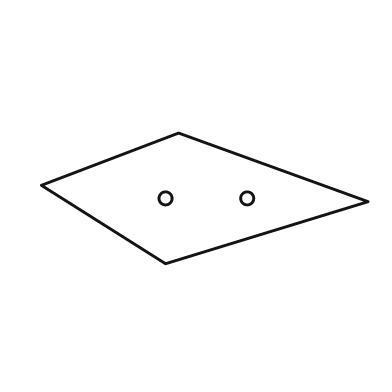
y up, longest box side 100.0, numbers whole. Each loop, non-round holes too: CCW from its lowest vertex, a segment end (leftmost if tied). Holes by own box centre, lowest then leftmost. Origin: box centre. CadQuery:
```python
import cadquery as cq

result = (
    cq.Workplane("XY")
    .moveTo(-12.0, -20.0)
    .lineTo(50.0, -1.0)
    .lineTo(-8.0, 20.0)
    .lineTo(-50.0, 4.0)
    .close()
    .moveTo(-12.0, 0.0)
    .circle(2.0)
    .moveTo(13.0, 0.0)
    .circle(2.0)
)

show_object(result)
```